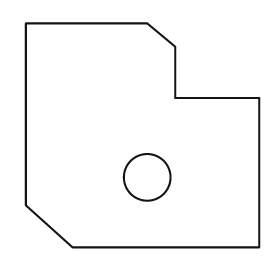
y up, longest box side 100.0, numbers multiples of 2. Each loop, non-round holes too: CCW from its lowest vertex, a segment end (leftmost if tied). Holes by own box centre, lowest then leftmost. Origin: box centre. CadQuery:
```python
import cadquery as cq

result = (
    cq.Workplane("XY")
    .moveTo(-30.0, -48.0)
    .lineTo(50.0, -48.0)
    .lineTo(50.0, 16.0)
    .lineTo(14.0, 16.0)
    .lineTo(14.0, 38.0)
    .lineTo(2.0, 48.0)
    .lineTo(-50.0, 48.0)
    .lineTo(-50.0, -30.0)
    .close()
    .moveTo(2.0, -18.0)
    .circle(10.0)
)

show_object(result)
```